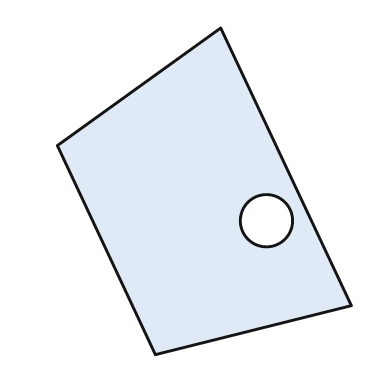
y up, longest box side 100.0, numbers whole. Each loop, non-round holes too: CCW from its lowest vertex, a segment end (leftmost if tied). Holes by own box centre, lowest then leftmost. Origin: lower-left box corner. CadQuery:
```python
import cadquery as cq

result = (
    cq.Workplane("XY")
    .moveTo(30.0, 0.0)
    .lineTo(90.0, 15.0)
    .lineTo(50.0, 100.0)
    .lineTo(0.0, 64.0)
    .close()
    .moveTo(64.0, 41.0)
    .circle(8.0)
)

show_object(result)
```